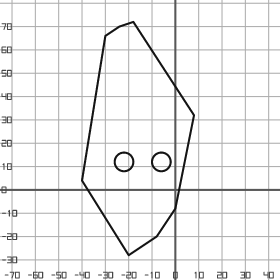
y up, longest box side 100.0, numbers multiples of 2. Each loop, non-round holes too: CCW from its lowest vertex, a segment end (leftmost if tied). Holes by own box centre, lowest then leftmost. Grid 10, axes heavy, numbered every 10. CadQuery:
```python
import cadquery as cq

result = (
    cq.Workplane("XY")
    .moveTo(-20.0, -28.0)
    .lineTo(-8.0, -20.0)
    .lineTo(0.0, -8.0)
    .lineTo(8.0, 32.0)
    .lineTo(-18.0, 72.0)
    .lineTo(-24.0, 70.0)
    .lineTo(-30.0, 66.0)
    .lineTo(-40.0, 4.0)
    .close()
    .moveTo(-22.0, 12.0)
    .circle(4.0)
    .moveTo(-6.0, 12.0)
    .circle(4.0)
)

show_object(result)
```